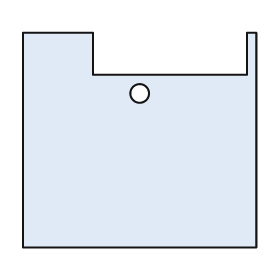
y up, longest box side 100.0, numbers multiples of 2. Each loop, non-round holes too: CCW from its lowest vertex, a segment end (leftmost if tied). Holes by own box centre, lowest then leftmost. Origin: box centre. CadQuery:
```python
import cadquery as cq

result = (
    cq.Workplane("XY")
    .moveTo(-50.0, -46.0)
    .lineTo(50.0, -46.0)
    .lineTo(50.0, 46.0)
    .lineTo(46.0, 46.0)
    .lineTo(46.0, 28.0)
    .lineTo(-20.0, 28.0)
    .lineTo(-20.0, 46.0)
    .lineTo(-50.0, 46.0)
    .close()
    .moveTo(0.0, 20.0)
    .circle(4.0)
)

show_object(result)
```